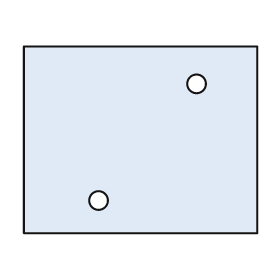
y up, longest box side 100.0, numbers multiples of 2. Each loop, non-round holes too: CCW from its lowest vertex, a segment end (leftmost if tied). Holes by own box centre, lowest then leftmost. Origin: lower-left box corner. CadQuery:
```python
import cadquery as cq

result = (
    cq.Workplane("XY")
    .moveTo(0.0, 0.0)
    .lineTo(100.0, 0.0)
    .lineTo(100.0, 80.0)
    .lineTo(0.0, 80.0)
    .close()
    .moveTo(32.0, 14.0)
    .circle(4.0)
    .moveTo(74.0, 64.0)
    .circle(4.0)
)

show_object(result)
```